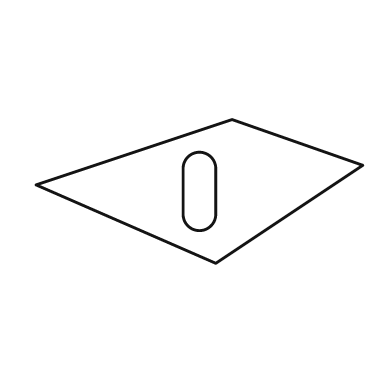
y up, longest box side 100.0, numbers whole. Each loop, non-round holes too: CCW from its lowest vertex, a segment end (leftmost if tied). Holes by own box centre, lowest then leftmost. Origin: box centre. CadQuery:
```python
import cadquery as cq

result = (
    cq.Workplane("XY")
    .moveTo(5.0, -22.0)
    .lineTo(50.0, 8.0)
    .lineTo(10.0, 22.0)
    .lineTo(-50.0, 2.0)
    .close()
    .moveTo(-5.0, -7.0)
    .threePointArc((0.0, -12.0), (5.0, -7.0))
    .lineTo(5.0, 7.0)
    .threePointArc((0.0, 12.0), (-5.0, 7.0))
    .close()
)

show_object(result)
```